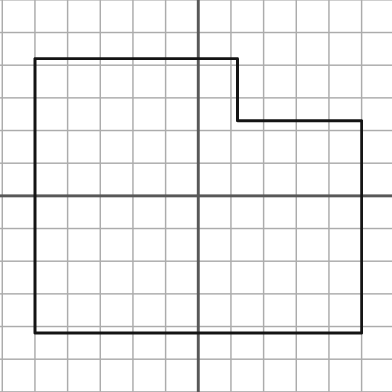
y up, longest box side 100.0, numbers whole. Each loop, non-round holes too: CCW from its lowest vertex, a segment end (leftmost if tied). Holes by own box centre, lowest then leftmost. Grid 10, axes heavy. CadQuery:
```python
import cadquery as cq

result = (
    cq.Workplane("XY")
    .moveTo(-50.0, -42.0)
    .lineTo(50.0, -42.0)
    .lineTo(50.0, 23.0)
    .lineTo(12.0, 23.0)
    .lineTo(12.0, 42.0)
    .lineTo(-50.0, 42.0)
    .close()
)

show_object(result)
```